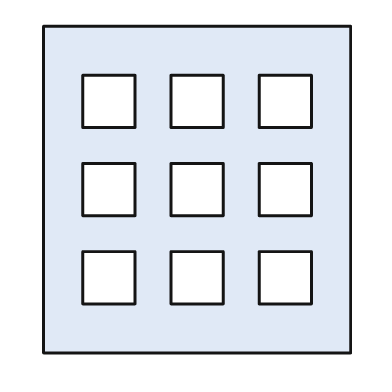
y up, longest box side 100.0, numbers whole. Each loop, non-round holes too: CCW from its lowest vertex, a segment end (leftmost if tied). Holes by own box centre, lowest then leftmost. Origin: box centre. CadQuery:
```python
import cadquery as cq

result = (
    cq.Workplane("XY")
    .moveTo(-47.0, -50.0)
    .lineTo(47.0, -50.0)
    .lineTo(47.0, 50.0)
    .lineTo(-47.0, 50.0)
    .close()
    .moveTo(-35.0, -35.0)
    .lineTo(-19.0, -35.0)
    .lineTo(-19.0, -19.0)
    .lineTo(-35.0, -19.0)
    .close()
    .moveTo(-8.0, -35.0)
    .lineTo(8.0, -35.0)
    .lineTo(8.0, -19.0)
    .lineTo(-8.0, -19.0)
    .close()
    .moveTo(19.0, -35.0)
    .lineTo(35.0, -35.0)
    .lineTo(35.0, -19.0)
    .lineTo(19.0, -19.0)
    .close()
    .moveTo(-35.0, -8.0)
    .lineTo(-19.0, -8.0)
    .lineTo(-19.0, 8.0)
    .lineTo(-35.0, 8.0)
    .close()
    .moveTo(-8.0, -8.0)
    .lineTo(8.0, -8.0)
    .lineTo(8.0, 8.0)
    .lineTo(-8.0, 8.0)
    .close()
    .moveTo(19.0, -8.0)
    .lineTo(35.0, -8.0)
    .lineTo(35.0, 8.0)
    .lineTo(19.0, 8.0)
    .close()
    .moveTo(-35.0, 19.0)
    .lineTo(-19.0, 19.0)
    .lineTo(-19.0, 35.0)
    .lineTo(-35.0, 35.0)
    .close()
    .moveTo(-8.0, 19.0)
    .lineTo(8.0, 19.0)
    .lineTo(8.0, 35.0)
    .lineTo(-8.0, 35.0)
    .close()
    .moveTo(19.0, 19.0)
    .lineTo(35.0, 19.0)
    .lineTo(35.0, 35.0)
    .lineTo(19.0, 35.0)
    .close()
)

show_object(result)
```